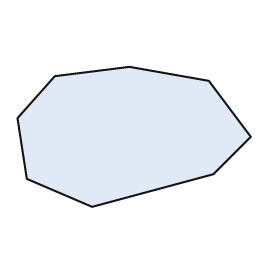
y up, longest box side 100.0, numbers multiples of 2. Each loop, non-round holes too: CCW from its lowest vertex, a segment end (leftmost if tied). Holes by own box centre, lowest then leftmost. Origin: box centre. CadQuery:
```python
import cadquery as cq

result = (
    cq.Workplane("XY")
    .moveTo(-18.0, -30.0)
    .lineTo(34.0, -16.0)
    .lineTo(50.0, 0.0)
    .lineTo(32.0, 24.0)
    .lineTo(-2.0, 30.0)
    .lineTo(-34.0, 26.0)
    .lineTo(-50.0, 8.0)
    .lineTo(-46.0, -18.0)
    .close()
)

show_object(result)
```